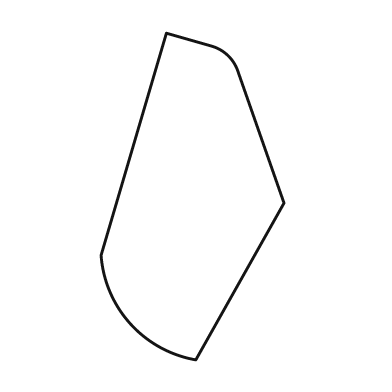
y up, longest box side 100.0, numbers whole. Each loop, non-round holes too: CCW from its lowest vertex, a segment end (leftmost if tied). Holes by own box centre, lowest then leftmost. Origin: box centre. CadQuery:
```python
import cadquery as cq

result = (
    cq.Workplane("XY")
    .moveTo(1.0, -50.0)
    .lineTo(28.0, -2.0)
    .lineTo(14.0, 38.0)
    .threePointArc((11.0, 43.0), (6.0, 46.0))
    .lineTo(-8.0, 50.0)
    .lineTo(-28.0, -18.0)
    .threePointArc((-19.0, -39.0), (1.0, -50.0))
    .close()
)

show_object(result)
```